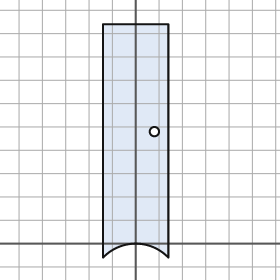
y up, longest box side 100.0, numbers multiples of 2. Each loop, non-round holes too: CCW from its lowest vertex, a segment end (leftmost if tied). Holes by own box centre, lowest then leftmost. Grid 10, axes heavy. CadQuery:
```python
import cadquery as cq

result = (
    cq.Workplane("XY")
    .moveTo(-14.0, -6.0)
    .threePointArc((0.0, 0.0), (14.0, -6.0))
    .lineTo(14.0, 94.0)
    .lineTo(-14.0, 94.0)
    .close()
    .moveTo(8.0, 48.0)
    .circle(2.0)
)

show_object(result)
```